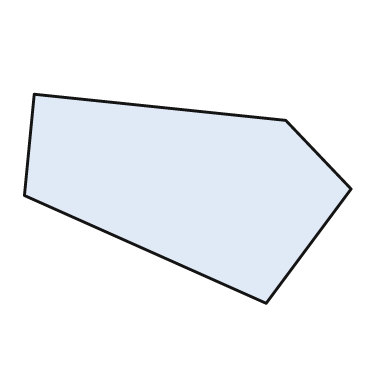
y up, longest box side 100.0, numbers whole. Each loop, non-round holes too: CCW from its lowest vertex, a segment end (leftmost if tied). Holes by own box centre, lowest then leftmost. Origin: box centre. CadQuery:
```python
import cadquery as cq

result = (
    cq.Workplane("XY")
    .moveTo(24.0, -32.0)
    .lineTo(50.0, 3.0)
    .lineTo(30.0, 24.0)
    .lineTo(-47.0, 32.0)
    .lineTo(-50.0, 1.0)
    .close()
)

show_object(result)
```